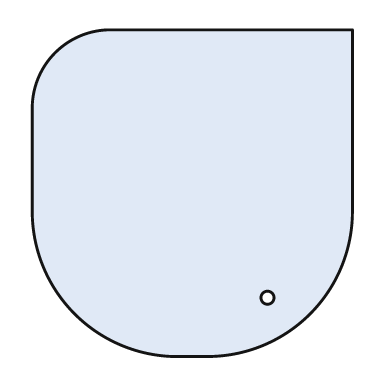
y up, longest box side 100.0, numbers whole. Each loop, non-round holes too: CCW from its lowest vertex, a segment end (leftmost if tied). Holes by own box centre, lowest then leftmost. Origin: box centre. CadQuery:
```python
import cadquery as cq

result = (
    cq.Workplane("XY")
    .moveTo(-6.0, -50.0)
    .lineTo(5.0, -50.0)
    .threePointArc((36.0, -37.0), (49.0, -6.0))
    .lineTo(49.0, 50.0)
    .lineTo(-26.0, 50.0)
    .threePointArc((-42.0, 43.0), (-49.0, 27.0))
    .lineTo(-49.0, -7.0)
    .threePointArc((-36.0, -37.0), (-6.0, -50.0))
    .close()
    .moveTo(23.0, -32.0)
    .circle(2.0)
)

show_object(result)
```